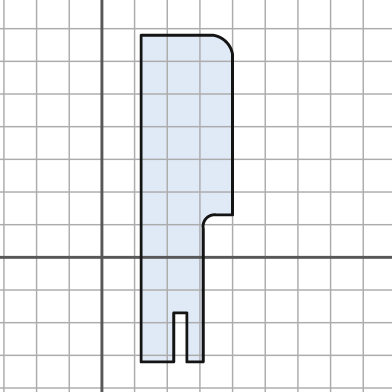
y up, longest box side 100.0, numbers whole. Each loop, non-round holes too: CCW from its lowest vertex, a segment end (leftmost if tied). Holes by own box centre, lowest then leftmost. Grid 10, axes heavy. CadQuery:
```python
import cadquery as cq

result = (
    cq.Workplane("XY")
    .moveTo(12.0, -32.0)
    .lineTo(22.0, -32.0)
    .lineTo(22.0, -17.0)
    .lineTo(26.0, -17.0)
    .lineTo(26.0, -32.0)
    .lineTo(31.0, -32.0)
    .lineTo(31.0, 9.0)
    .threePointArc((32.0, 12.0), (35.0, 13.0))
    .lineTo(40.0, 13.0)
    .lineTo(40.0, 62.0)
    .threePointArc((38.0, 66.0), (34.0, 68.0))
    .lineTo(12.0, 68.0)
    .close()
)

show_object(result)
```